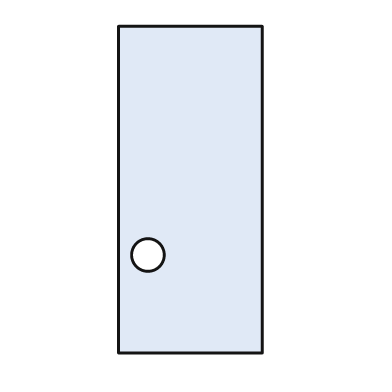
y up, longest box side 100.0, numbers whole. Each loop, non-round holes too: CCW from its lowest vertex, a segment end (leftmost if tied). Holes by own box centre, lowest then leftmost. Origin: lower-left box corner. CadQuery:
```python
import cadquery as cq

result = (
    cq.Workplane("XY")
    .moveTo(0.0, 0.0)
    .lineTo(44.0, 0.0)
    .lineTo(44.0, 100.0)
    .lineTo(0.0, 100.0)
    .close()
    .moveTo(9.0, 30.0)
    .circle(5.0)
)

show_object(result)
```